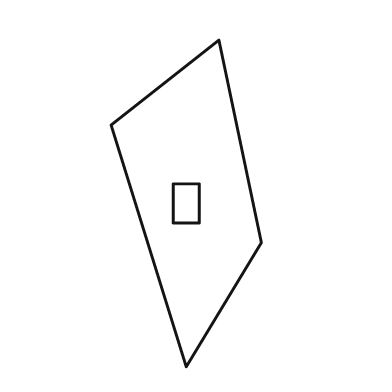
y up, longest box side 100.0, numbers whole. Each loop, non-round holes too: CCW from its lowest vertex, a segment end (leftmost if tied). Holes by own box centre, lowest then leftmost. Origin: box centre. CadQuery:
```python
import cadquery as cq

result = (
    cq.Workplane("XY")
    .moveTo(0.0, -50.0)
    .lineTo(23.0, -12.0)
    .lineTo(10.0, 50.0)
    .lineTo(-23.0, 24.0)
    .close()
    .moveTo(-4.0, -6.0)
    .lineTo(4.0, -6.0)
    .lineTo(4.0, 6.0)
    .lineTo(-4.0, 6.0)
    .close()
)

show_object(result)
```